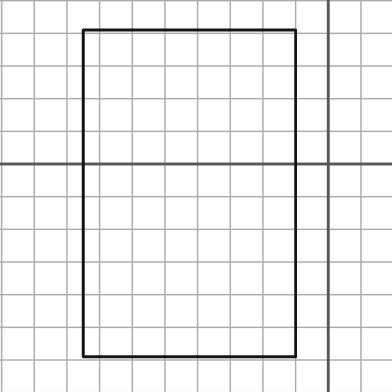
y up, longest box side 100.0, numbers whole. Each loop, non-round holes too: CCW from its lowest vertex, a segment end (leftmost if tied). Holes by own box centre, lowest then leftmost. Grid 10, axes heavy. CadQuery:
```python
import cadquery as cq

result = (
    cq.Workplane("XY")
    .moveTo(-75.0, -59.0)
    .lineTo(-10.0, -59.0)
    .lineTo(-10.0, 41.0)
    .lineTo(-75.0, 41.0)
    .close()
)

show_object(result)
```